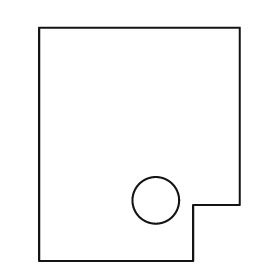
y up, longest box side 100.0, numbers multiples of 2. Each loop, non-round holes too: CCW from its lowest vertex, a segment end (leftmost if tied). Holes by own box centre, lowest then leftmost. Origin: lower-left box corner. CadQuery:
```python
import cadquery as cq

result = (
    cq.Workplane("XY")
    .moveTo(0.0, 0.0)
    .lineTo(66.0, 0.0)
    .lineTo(66.0, 24.0)
    .lineTo(86.0, 24.0)
    .lineTo(86.0, 100.0)
    .lineTo(0.0, 100.0)
    .close()
    .moveTo(50.0, 26.0)
    .circle(10.0)
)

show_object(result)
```